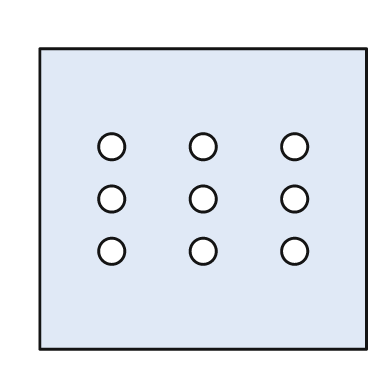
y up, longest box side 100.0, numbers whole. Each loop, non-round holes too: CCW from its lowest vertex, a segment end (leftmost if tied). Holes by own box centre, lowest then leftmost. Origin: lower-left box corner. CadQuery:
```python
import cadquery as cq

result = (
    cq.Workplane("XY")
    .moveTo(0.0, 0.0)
    .lineTo(100.0, 0.0)
    .lineTo(100.0, 92.0)
    .lineTo(0.0, 92.0)
    .close()
    .moveTo(22.0, 30.0)
    .circle(4.0)
    .moveTo(50.0, 30.0)
    .circle(4.0)
    .moveTo(78.0, 30.0)
    .circle(4.0)
    .moveTo(22.0, 46.0)
    .circle(4.0)
    .moveTo(50.0, 46.0)
    .circle(4.0)
    .moveTo(78.0, 46.0)
    .circle(4.0)
    .moveTo(22.0, 62.0)
    .circle(4.0)
    .moveTo(50.0, 62.0)
    .circle(4.0)
    .moveTo(78.0, 62.0)
    .circle(4.0)
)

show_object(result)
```